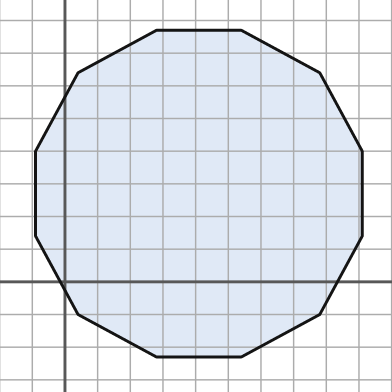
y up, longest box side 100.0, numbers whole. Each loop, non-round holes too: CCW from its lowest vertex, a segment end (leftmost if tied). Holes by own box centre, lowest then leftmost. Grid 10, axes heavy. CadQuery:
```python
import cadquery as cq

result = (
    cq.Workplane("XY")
    .moveTo(28.0, -23.0)
    .lineTo(54.0, -23.0)
    .lineTo(78.0, -10.0)
    .lineTo(91.0, 14.0)
    .lineTo(91.0, 40.0)
    .lineTo(78.0, 64.0)
    .lineTo(54.0, 77.0)
    .lineTo(28.0, 77.0)
    .lineTo(4.0, 64.0)
    .lineTo(-9.0, 40.0)
    .lineTo(-9.0, 14.0)
    .lineTo(4.0, -10.0)
    .close()
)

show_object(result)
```